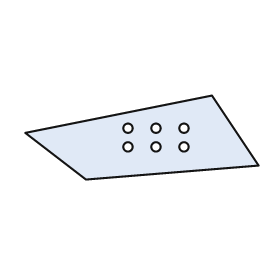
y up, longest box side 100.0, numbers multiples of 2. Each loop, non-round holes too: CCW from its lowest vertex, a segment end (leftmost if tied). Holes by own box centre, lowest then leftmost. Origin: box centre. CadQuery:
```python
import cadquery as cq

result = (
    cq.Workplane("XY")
    .moveTo(-24.0, -18.0)
    .lineTo(50.0, -12.0)
    .lineTo(30.0, 18.0)
    .lineTo(-50.0, 2.0)
    .close()
    .moveTo(-6.0, -4.0)
    .circle(2.0)
    .moveTo(6.0, -4.0)
    .circle(2.0)
    .moveTo(18.0, -4.0)
    .circle(2.0)
    .moveTo(-6.0, 4.0)
    .circle(2.0)
    .moveTo(6.0, 4.0)
    .circle(2.0)
    .moveTo(18.0, 4.0)
    .circle(2.0)
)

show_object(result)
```